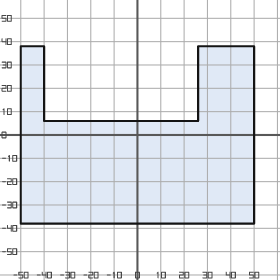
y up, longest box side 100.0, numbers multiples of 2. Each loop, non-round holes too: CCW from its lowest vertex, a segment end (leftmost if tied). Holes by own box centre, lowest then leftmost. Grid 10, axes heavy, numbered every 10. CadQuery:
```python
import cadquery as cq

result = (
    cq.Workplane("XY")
    .moveTo(-50.0, -38.0)
    .lineTo(50.0, -38.0)
    .lineTo(50.0, 38.0)
    .lineTo(26.0, 38.0)
    .lineTo(26.0, 6.0)
    .lineTo(-40.0, 6.0)
    .lineTo(-40.0, 38.0)
    .lineTo(-50.0, 38.0)
    .close()
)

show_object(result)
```